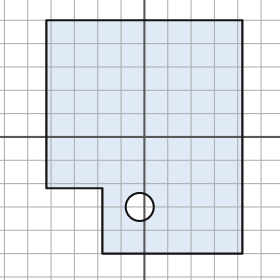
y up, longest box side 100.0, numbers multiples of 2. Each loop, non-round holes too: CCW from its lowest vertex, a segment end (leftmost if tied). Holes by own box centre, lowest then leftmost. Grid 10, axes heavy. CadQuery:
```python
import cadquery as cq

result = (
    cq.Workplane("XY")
    .moveTo(-18.0, -50.0)
    .lineTo(42.0, -50.0)
    .lineTo(42.0, 50.0)
    .lineTo(-42.0, 50.0)
    .lineTo(-42.0, -22.0)
    .lineTo(-18.0, -22.0)
    .close()
    .moveTo(-2.0, -30.0)
    .circle(6.0)
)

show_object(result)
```